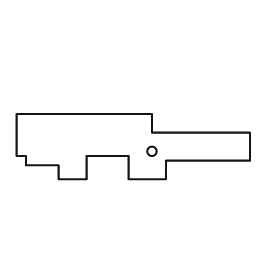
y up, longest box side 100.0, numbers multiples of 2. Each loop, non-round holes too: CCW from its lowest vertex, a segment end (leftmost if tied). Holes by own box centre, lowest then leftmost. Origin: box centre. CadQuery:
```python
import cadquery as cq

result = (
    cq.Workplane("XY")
    .moveTo(-32.0, -14.0)
    .lineTo(-20.0, -14.0)
    .lineTo(-20.0, -4.0)
    .lineTo(-2.0, -4.0)
    .lineTo(-2.0, -14.0)
    .lineTo(14.0, -14.0)
    .lineTo(14.0, -6.0)
    .lineTo(50.0, -6.0)
    .lineTo(50.0, 6.0)
    .lineTo(8.0, 6.0)
    .lineTo(8.0, 14.0)
    .lineTo(-50.0, 14.0)
    .lineTo(-50.0, -4.0)
    .lineTo(-46.0, -4.0)
    .lineTo(-46.0, -8.0)
    .lineTo(-32.0, -8.0)
    .close()
    .moveTo(8.0, -2.0)
    .circle(2.0)
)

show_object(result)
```